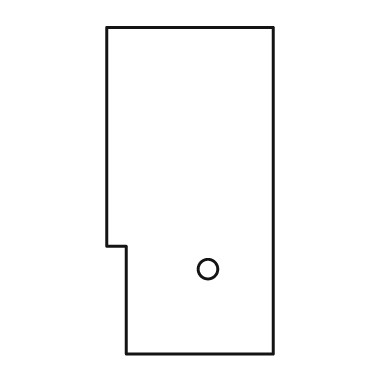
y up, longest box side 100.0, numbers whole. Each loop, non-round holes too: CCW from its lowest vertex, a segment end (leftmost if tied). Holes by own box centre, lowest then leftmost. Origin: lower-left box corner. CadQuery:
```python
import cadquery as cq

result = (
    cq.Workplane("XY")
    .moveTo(6.0, 0.0)
    .lineTo(51.0, 0.0)
    .lineTo(51.0, 100.0)
    .lineTo(0.0, 100.0)
    .lineTo(0.0, 33.0)
    .lineTo(6.0, 33.0)
    .close()
    .moveTo(31.0, 26.0)
    .circle(3.0)
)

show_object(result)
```